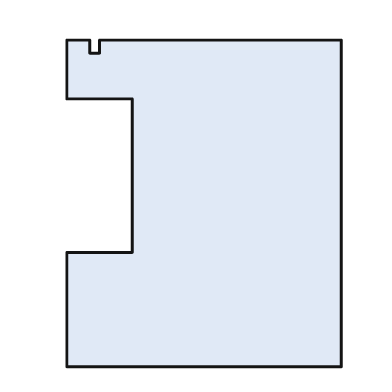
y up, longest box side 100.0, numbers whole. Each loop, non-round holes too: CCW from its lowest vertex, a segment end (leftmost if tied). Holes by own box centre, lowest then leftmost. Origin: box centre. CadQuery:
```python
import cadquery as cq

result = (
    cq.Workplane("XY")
    .moveTo(-42.0, -50.0)
    .lineTo(42.0, -50.0)
    .lineTo(42.0, 50.0)
    .lineTo(-32.0, 50.0)
    .lineTo(-32.0, 46.0)
    .lineTo(-35.0, 46.0)
    .lineTo(-35.0, 50.0)
    .lineTo(-42.0, 50.0)
    .lineTo(-42.0, 32.0)
    .lineTo(-22.0, 32.0)
    .lineTo(-22.0, -15.0)
    .lineTo(-42.0, -15.0)
    .close()
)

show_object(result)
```